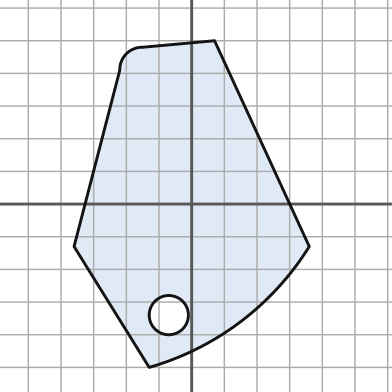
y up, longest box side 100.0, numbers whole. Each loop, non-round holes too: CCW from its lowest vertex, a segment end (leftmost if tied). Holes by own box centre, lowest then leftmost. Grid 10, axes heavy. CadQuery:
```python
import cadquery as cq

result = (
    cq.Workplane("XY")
    .moveTo(-13.0, -50.0)
    .threePointArc((15.0, -36.0), (36.0, -13.0))
    .lineTo(7.0, 50.0)
    .lineTo(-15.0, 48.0)
    .threePointArc((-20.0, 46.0), (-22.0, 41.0))
    .lineTo(-36.0, -13.0)
    .close()
    .moveTo(-7.0, -34.0)
    .circle(6.0)
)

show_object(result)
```